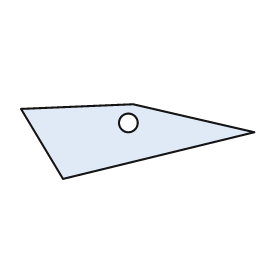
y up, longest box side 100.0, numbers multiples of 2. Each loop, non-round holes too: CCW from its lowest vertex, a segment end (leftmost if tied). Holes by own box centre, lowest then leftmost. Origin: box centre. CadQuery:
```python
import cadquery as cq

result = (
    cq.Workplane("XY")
    .moveTo(-32.0, -16.0)
    .lineTo(50.0, 4.0)
    .lineTo(-2.0, 16.0)
    .lineTo(-50.0, 14.0)
    .close()
    .moveTo(-4.0, 8.0)
    .circle(4.0)
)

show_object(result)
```